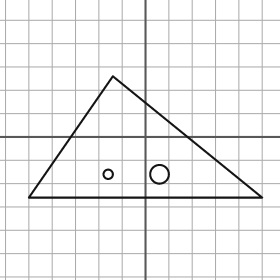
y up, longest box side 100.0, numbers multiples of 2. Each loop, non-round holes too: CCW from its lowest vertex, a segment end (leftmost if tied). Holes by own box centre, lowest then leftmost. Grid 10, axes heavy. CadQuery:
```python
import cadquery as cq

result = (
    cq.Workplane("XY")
    .moveTo(-50.0, -26.0)
    .lineTo(50.0, -26.0)
    .lineTo(-14.0, 26.0)
    .close()
    .moveTo(-16.0, -16.0)
    .circle(2.0)
    .moveTo(6.0, -16.0)
    .circle(4.0)
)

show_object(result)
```